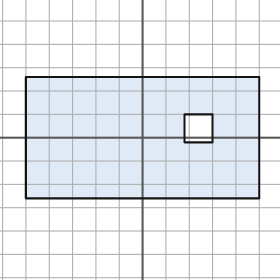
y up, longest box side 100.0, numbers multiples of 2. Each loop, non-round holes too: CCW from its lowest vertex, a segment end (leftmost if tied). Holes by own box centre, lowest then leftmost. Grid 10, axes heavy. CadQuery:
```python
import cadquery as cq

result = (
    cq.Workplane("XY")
    .moveTo(-50.0, -26.0)
    .lineTo(50.0, -26.0)
    .lineTo(50.0, 26.0)
    .lineTo(-50.0, 26.0)
    .close()
    .moveTo(18.0, -2.0)
    .lineTo(30.0, -2.0)
    .lineTo(30.0, 10.0)
    .lineTo(18.0, 10.0)
    .close()
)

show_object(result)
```